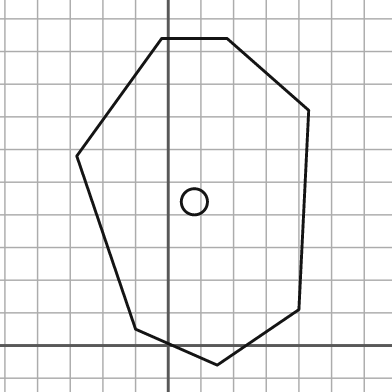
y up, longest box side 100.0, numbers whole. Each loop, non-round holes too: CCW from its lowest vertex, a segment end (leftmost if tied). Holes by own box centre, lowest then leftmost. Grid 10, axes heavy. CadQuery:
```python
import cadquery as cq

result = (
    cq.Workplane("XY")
    .moveTo(15.0, -6.0)
    .lineTo(40.0, 11.0)
    .lineTo(43.0, 72.0)
    .lineTo(18.0, 94.0)
    .lineTo(-2.0, 94.0)
    .lineTo(-28.0, 58.0)
    .lineTo(-10.0, 5.0)
    .close()
    .moveTo(8.0, 44.0)
    .circle(4.0)
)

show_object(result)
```